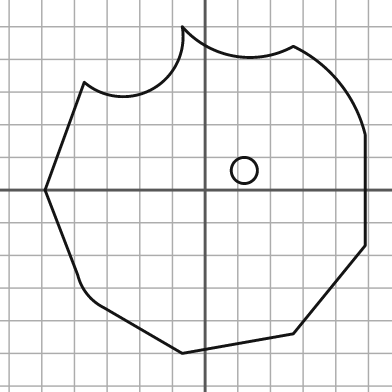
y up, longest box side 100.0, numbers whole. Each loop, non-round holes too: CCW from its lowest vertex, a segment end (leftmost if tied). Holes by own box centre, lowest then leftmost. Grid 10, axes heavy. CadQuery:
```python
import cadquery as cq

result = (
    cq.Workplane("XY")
    .moveTo(-7.0, -50.0)
    .lineTo(27.0, -44.0)
    .lineTo(49.0, -17.0)
    .lineTo(49.0, 17.0)
    .threePointArc((41.0, 33.0), (27.0, 44.0))
    .threePointArc((9.0, 41.0), (-7.0, 50.0))
    .threePointArc((-16.0, 31.0), (-37.0, 33.0))
    .lineTo(-49.0, 0.0)
    .lineTo(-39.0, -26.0)
    .threePointArc((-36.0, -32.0), (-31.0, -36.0))
    .close()
    .moveTo(12.0, 6.0)
    .circle(4.0)
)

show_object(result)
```